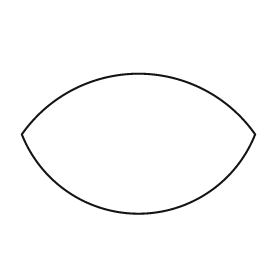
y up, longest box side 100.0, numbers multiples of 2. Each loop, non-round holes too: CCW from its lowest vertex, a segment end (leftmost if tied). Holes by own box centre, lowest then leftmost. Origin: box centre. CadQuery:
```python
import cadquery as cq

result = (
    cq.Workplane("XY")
    .moveTo(-50.0, 4.0)
    .threePointArc((0.0, -30.0), (50.0, 4.0))
    .threePointArc((0.0, 30.0), (-50.0, 4.0))
    .close()
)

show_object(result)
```